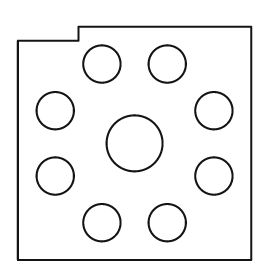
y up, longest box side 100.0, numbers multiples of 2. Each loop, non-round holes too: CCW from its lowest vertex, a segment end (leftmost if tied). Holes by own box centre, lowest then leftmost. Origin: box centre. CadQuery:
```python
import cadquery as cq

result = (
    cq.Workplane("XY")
    .moveTo(-50.0, -50.0)
    .lineTo(50.0, -50.0)
    .lineTo(50.0, 50.0)
    .lineTo(-24.0, 50.0)
    .lineTo(-24.0, 44.0)
    .lineTo(-50.0, 44.0)
    .close()
    .moveTo(-14.0, -34.0)
    .circle(8.0)
    .moveTo(14.0, -34.0)
    .circle(8.0)
    .moveTo(-34.0, -14.0)
    .circle(8.0)
    .moveTo(34.0, -14.0)
    .circle(8.0)
    .moveTo(0.0, 0.0)
    .circle(12.0)
    .moveTo(-34.0, 14.0)
    .circle(8.0)
    .moveTo(34.0, 14.0)
    .circle(8.0)
    .moveTo(-14.0, 34.0)
    .circle(8.0)
    .moveTo(14.0, 34.0)
    .circle(8.0)
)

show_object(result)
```